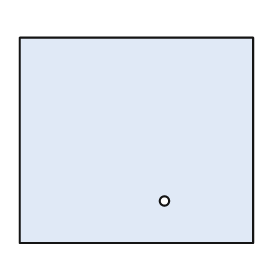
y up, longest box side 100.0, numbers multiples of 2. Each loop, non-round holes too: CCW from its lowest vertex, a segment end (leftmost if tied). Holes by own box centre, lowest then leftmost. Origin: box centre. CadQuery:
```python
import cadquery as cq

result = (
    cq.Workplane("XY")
    .moveTo(-50.0, -44.0)
    .lineTo(50.0, -44.0)
    .lineTo(50.0, 44.0)
    .lineTo(-50.0, 44.0)
    .close()
    .moveTo(12.0, -26.0)
    .circle(2.0)
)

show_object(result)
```